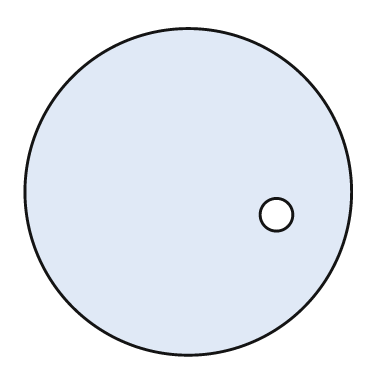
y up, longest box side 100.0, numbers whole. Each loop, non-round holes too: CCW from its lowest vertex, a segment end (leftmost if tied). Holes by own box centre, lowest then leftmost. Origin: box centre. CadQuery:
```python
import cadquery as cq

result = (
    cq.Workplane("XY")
    .moveTo(0.0, 0.0)
    .circle(50.0)
    .moveTo(27.0, -7.0)
    .circle(5.0)
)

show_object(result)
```